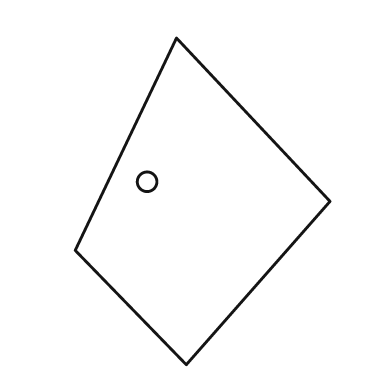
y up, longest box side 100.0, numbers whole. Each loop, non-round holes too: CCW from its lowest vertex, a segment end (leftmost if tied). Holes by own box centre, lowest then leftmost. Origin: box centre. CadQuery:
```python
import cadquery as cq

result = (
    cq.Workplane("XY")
    .moveTo(-5.0, -50.0)
    .lineTo(39.0, 0.0)
    .lineTo(-8.0, 50.0)
    .lineTo(-39.0, -15.0)
    .close()
    .moveTo(-17.0, 6.0)
    .circle(3.0)
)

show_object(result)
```